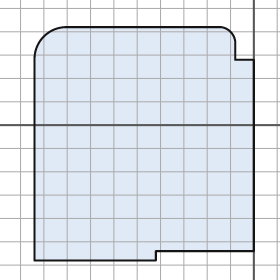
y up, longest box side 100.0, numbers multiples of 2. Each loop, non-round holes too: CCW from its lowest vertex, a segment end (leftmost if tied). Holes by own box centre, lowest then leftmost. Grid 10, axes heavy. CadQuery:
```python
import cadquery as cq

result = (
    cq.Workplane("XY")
    .moveTo(-94.0, -58.0)
    .lineTo(-42.0, -58.0)
    .lineTo(-42.0, -54.0)
    .lineTo(0.0, -54.0)
    .lineTo(0.0, 28.0)
    .lineTo(-8.0, 28.0)
    .lineTo(-8.0, 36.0)
    .threePointArc((-10.0, 40.0), (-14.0, 42.0))
    .lineTo(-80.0, 42.0)
    .threePointArc((-90.0, 38.0), (-94.0, 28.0))
    .close()
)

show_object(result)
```